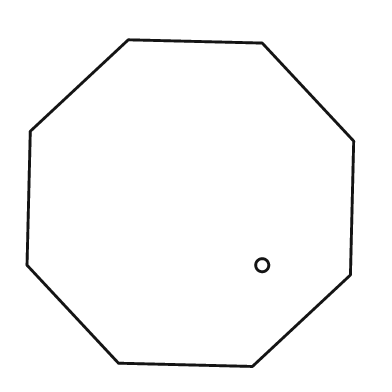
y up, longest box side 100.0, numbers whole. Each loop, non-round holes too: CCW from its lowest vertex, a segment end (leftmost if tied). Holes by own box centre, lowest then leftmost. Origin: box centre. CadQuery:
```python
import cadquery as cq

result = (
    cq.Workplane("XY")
    .moveTo(19.0, -50.0)
    .lineTo(49.0, -22.0)
    .lineTo(50.0, 19.0)
    .lineTo(22.0, 49.0)
    .lineTo(-19.0, 50.0)
    .lineTo(-49.0, 22.0)
    .lineTo(-50.0, -19.0)
    .lineTo(-22.0, -49.0)
    .close()
    .moveTo(22.0, -19.0)
    .circle(2.0)
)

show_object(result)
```